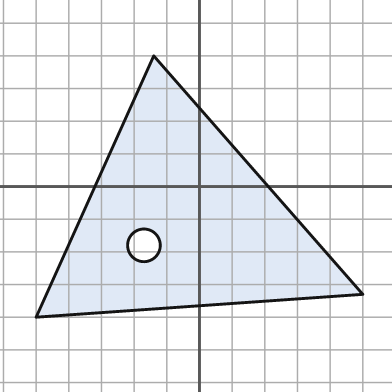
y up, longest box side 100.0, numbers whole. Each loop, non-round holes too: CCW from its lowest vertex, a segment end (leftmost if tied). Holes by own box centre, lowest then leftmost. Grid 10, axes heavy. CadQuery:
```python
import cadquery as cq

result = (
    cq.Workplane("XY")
    .moveTo(-50.0, -40.0)
    .lineTo(50.0, -33.0)
    .lineTo(-14.0, 40.0)
    .close()
    .moveTo(-17.0, -18.0)
    .circle(5.0)
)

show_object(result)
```